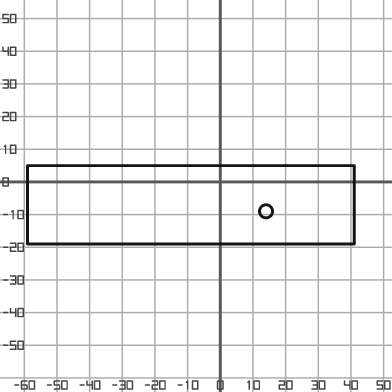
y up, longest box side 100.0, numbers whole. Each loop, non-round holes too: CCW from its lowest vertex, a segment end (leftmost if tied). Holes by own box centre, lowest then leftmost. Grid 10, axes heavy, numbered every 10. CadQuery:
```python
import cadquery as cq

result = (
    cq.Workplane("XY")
    .moveTo(-59.0, -19.0)
    .lineTo(41.0, -19.0)
    .lineTo(41.0, 5.0)
    .lineTo(-59.0, 5.0)
    .close()
    .moveTo(14.0, -9.0)
    .circle(2.0)
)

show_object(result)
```